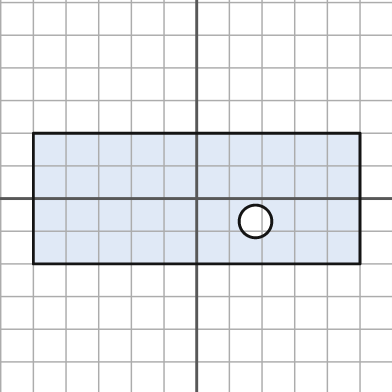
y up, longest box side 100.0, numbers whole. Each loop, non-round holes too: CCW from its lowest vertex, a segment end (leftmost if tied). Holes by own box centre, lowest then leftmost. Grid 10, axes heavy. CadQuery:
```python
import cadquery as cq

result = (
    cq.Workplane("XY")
    .moveTo(-50.0, -20.0)
    .lineTo(50.0, -20.0)
    .lineTo(50.0, 20.0)
    .lineTo(-50.0, 20.0)
    .close()
    .moveTo(18.0, -7.0)
    .circle(5.0)
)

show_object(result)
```